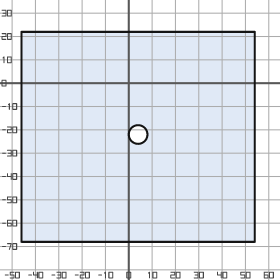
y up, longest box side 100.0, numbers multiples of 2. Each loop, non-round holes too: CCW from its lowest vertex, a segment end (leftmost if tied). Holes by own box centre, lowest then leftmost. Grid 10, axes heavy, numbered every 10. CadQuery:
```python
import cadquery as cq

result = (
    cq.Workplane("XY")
    .moveTo(-46.0, -68.0)
    .lineTo(54.0, -68.0)
    .lineTo(54.0, 22.0)
    .lineTo(-46.0, 22.0)
    .close()
    .moveTo(4.0, -22.0)
    .circle(4.0)
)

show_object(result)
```